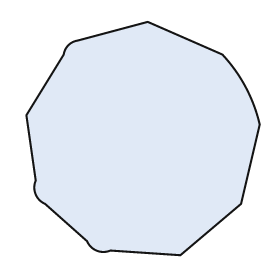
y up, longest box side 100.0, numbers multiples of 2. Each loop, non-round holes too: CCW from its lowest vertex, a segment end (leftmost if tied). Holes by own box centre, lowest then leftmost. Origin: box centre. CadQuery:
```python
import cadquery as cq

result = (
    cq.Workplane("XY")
    .moveTo(16.0, -50.0)
    .lineTo(42.0, -28.0)
    .lineTo(50.0, 6.0)
    .threePointArc((44.0, 22.0), (34.0, 36.0))
    .lineTo(2.0, 50.0)
    .lineTo(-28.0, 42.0)
    .threePointArc((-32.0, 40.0), (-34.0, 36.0))
    .lineTo(-50.0, 10.0)
    .lineTo(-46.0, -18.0)
    .threePointArc((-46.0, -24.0), (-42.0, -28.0))
    .lineTo(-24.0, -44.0)
    .threePointArc((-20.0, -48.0), (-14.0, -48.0))
    .close()
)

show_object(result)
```